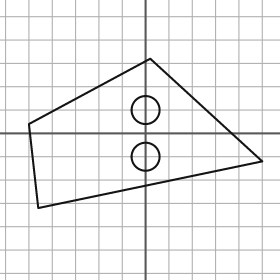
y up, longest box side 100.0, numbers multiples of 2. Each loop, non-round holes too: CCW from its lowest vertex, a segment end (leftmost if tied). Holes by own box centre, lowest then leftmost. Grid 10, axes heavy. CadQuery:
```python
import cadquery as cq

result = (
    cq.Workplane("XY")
    .moveTo(-46.0, -32.0)
    .lineTo(50.0, -12.0)
    .lineTo(2.0, 32.0)
    .lineTo(-50.0, 4.0)
    .close()
    .moveTo(0.0, -10.0)
    .circle(6.0)
    .moveTo(0.0, 10.0)
    .circle(6.0)
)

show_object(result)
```